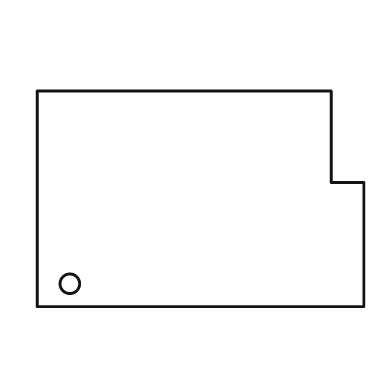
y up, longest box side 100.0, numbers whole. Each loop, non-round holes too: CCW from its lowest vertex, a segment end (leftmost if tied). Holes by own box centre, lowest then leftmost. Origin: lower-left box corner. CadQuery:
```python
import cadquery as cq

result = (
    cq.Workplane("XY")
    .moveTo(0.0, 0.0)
    .lineTo(100.0, 0.0)
    .lineTo(100.0, 38.0)
    .lineTo(90.0, 38.0)
    .lineTo(90.0, 66.0)
    .lineTo(0.0, 66.0)
    .close()
    .moveTo(10.0, 7.0)
    .circle(3.0)
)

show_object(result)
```